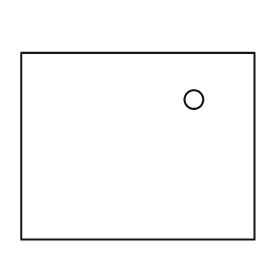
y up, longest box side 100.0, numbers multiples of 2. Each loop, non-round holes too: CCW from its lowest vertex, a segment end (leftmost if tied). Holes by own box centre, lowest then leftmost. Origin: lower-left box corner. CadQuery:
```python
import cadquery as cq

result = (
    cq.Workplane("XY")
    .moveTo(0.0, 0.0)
    .lineTo(100.0, 0.0)
    .lineTo(100.0, 80.0)
    .lineTo(0.0, 80.0)
    .close()
    .moveTo(74.0, 60.0)
    .circle(4.0)
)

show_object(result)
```